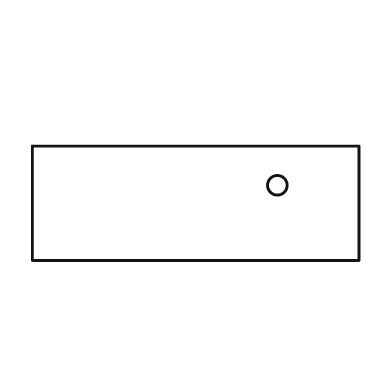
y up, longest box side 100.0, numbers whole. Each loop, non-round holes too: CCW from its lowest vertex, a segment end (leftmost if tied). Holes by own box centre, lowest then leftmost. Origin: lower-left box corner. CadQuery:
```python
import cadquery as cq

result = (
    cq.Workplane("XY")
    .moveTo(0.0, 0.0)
    .lineTo(100.0, 0.0)
    .lineTo(100.0, 35.0)
    .lineTo(0.0, 35.0)
    .close()
    .moveTo(75.0, 23.0)
    .circle(3.0)
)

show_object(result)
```